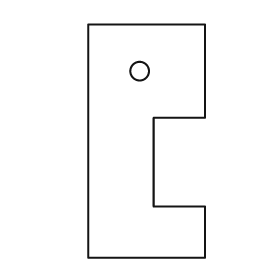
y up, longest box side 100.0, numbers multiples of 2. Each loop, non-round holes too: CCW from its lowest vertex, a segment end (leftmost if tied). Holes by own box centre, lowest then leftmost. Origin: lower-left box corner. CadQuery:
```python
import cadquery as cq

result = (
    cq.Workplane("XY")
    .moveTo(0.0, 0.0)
    .lineTo(50.0, 0.0)
    .lineTo(50.0, 22.0)
    .lineTo(28.0, 22.0)
    .lineTo(28.0, 60.0)
    .lineTo(50.0, 60.0)
    .lineTo(50.0, 100.0)
    .lineTo(0.0, 100.0)
    .close()
    .moveTo(22.0, 80.0)
    .circle(4.0)
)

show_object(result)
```